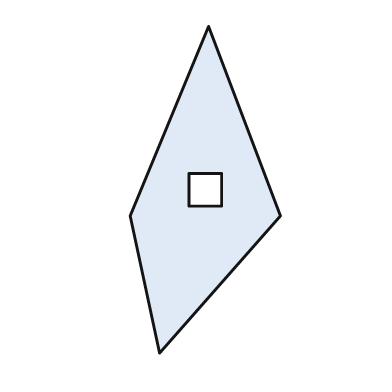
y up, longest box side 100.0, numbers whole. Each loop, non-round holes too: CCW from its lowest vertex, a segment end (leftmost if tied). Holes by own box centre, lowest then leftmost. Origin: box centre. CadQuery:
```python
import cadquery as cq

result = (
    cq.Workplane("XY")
    .moveTo(-14.0, -50.0)
    .lineTo(23.0, -8.0)
    .lineTo(1.0, 50.0)
    .lineTo(-23.0, -8.0)
    .close()
    .moveTo(-5.0, -5.0)
    .lineTo(5.0, -5.0)
    .lineTo(5.0, 5.0)
    .lineTo(-5.0, 5.0)
    .close()
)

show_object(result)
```